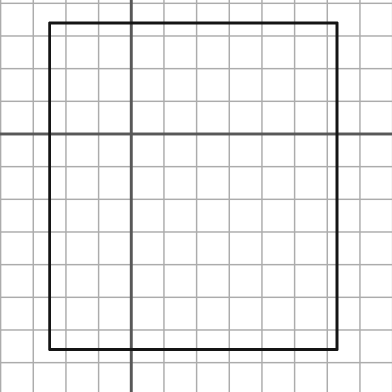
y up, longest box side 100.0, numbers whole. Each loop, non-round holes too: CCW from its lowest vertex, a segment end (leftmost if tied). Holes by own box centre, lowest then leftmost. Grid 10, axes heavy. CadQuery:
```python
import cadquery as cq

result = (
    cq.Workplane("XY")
    .moveTo(-25.0, -66.0)
    .lineTo(63.0, -66.0)
    .lineTo(63.0, 34.0)
    .lineTo(-25.0, 34.0)
    .close()
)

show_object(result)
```